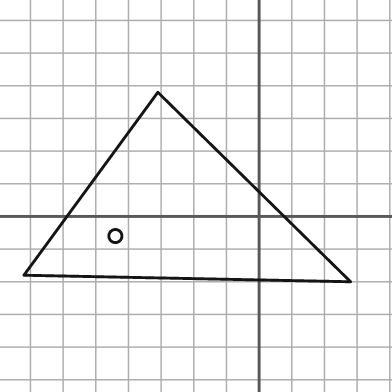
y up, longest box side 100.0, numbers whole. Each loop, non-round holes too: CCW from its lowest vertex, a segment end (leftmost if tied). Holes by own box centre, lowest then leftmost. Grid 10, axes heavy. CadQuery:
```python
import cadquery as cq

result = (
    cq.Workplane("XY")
    .moveTo(28.0, -20.0)
    .lineTo(-31.0, 38.0)
    .lineTo(-72.0, -18.0)
    .close()
    .moveTo(-44.0, -6.0)
    .circle(2.0)
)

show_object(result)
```